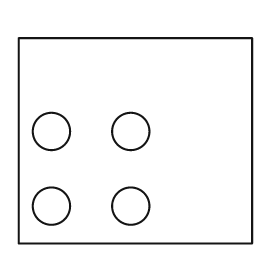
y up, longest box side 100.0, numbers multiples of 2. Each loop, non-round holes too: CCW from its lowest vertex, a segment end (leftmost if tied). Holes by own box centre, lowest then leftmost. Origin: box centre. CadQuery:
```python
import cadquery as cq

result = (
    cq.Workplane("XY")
    .moveTo(-50.0, -44.0)
    .lineTo(50.0, -44.0)
    .lineTo(50.0, 44.0)
    .lineTo(-50.0, 44.0)
    .close()
    .moveTo(-36.0, -28.0)
    .circle(8.0)
    .moveTo(-2.0, -28.0)
    .circle(8.0)
    .moveTo(-36.0, 4.0)
    .circle(8.0)
    .moveTo(-2.0, 4.0)
    .circle(8.0)
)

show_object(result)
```